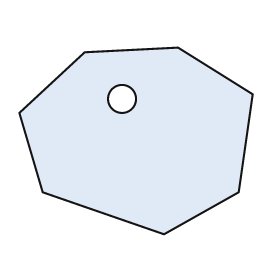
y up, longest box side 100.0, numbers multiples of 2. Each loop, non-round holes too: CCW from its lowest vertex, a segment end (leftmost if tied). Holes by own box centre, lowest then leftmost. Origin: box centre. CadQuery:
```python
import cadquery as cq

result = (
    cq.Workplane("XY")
    .moveTo(12.0, -40.0)
    .lineTo(44.0, -22.0)
    .lineTo(50.0, 20.0)
    .lineTo(18.0, 40.0)
    .lineTo(-22.0, 38.0)
    .lineTo(-50.0, 12.0)
    .lineTo(-40.0, -22.0)
    .close()
    .moveTo(-6.0, 18.0)
    .circle(6.0)
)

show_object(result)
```